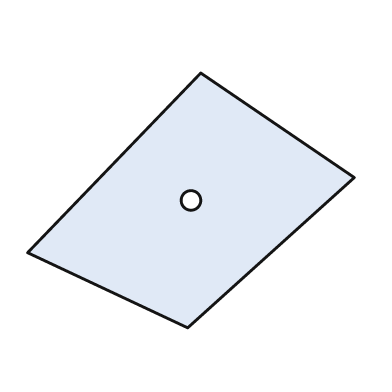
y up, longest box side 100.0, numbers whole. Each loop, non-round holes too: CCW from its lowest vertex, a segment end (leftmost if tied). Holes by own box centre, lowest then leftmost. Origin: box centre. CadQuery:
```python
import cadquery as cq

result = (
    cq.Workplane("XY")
    .moveTo(-1.0, -39.0)
    .lineTo(50.0, 7.0)
    .lineTo(3.0, 39.0)
    .lineTo(-50.0, -16.0)
    .close()
    .moveTo(0.0, 0.0)
    .circle(3.0)
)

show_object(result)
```